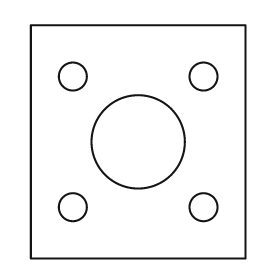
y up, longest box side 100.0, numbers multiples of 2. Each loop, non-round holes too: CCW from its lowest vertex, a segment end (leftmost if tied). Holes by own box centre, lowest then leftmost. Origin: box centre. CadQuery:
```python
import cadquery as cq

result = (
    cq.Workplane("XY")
    .moveTo(-46.0, -50.0)
    .lineTo(46.0, -50.0)
    .lineTo(46.0, 50.0)
    .lineTo(-46.0, 50.0)
    .close()
    .moveTo(-28.0, -28.0)
    .circle(6.0)
    .moveTo(28.0, -28.0)
    .circle(6.0)
    .moveTo(0.0, 0.0)
    .circle(20.0)
    .moveTo(-28.0, 28.0)
    .circle(6.0)
    .moveTo(28.0, 28.0)
    .circle(6.0)
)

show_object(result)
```